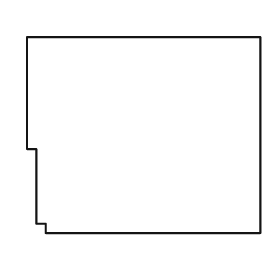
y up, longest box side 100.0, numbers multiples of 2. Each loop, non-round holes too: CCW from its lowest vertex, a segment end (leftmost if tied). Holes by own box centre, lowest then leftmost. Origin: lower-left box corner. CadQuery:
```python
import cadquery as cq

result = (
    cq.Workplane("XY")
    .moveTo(8.0, 0.0)
    .lineTo(100.0, 0.0)
    .lineTo(100.0, 84.0)
    .lineTo(0.0, 84.0)
    .lineTo(0.0, 36.0)
    .lineTo(4.0, 36.0)
    .lineTo(4.0, 4.0)
    .lineTo(8.0, 4.0)
    .close()
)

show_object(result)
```